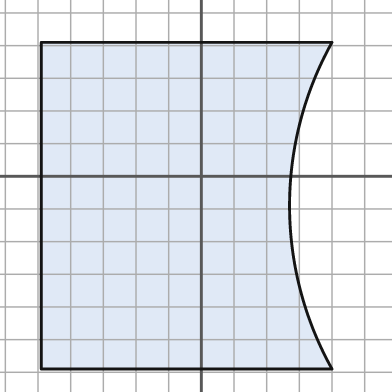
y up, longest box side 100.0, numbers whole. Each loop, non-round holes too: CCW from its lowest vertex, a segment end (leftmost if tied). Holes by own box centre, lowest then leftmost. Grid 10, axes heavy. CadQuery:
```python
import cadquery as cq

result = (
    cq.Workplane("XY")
    .moveTo(-49.0, -59.0)
    .lineTo(40.0, -59.0)
    .threePointArc((27.0, -9.0), (40.0, 41.0))
    .lineTo(-49.0, 41.0)
    .close()
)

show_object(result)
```